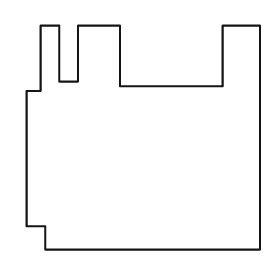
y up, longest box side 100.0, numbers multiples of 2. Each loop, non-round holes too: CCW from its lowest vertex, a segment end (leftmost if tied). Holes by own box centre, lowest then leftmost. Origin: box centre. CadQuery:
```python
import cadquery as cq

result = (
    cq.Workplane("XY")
    .moveTo(-42.0, -48.0)
    .lineTo(50.0, -48.0)
    .lineTo(50.0, 48.0)
    .lineTo(34.0, 48.0)
    .lineTo(34.0, 22.0)
    .lineTo(-10.0, 22.0)
    .lineTo(-10.0, 48.0)
    .lineTo(-28.0, 48.0)
    .lineTo(-28.0, 24.0)
    .lineTo(-36.0, 24.0)
    .lineTo(-36.0, 48.0)
    .lineTo(-44.0, 48.0)
    .lineTo(-44.0, 20.0)
    .lineTo(-50.0, 20.0)
    .lineTo(-50.0, -38.0)
    .lineTo(-42.0, -38.0)
    .close()
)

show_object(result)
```